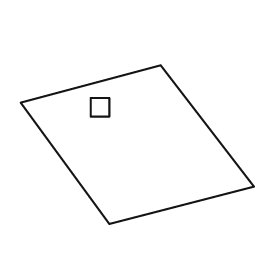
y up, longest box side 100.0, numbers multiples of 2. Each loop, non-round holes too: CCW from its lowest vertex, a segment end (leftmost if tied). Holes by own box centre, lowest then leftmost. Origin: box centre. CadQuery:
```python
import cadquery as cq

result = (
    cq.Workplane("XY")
    .moveTo(-12.0, -34.0)
    .lineTo(50.0, -18.0)
    .lineTo(10.0, 34.0)
    .lineTo(-50.0, 18.0)
    .close()
    .moveTo(-20.0, 12.0)
    .lineTo(-12.0, 12.0)
    .lineTo(-12.0, 20.0)
    .lineTo(-20.0, 20.0)
    .close()
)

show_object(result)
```